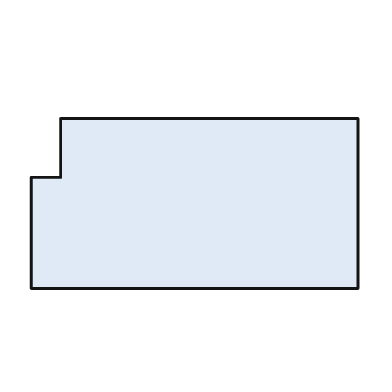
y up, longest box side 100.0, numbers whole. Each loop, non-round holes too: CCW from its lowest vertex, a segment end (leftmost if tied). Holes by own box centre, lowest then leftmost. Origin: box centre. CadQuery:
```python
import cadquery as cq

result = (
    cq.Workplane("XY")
    .moveTo(-50.0, -26.0)
    .lineTo(50.0, -26.0)
    .lineTo(50.0, 26.0)
    .lineTo(-41.0, 26.0)
    .lineTo(-41.0, 8.0)
    .lineTo(-50.0, 8.0)
    .close()
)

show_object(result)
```